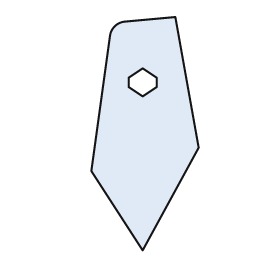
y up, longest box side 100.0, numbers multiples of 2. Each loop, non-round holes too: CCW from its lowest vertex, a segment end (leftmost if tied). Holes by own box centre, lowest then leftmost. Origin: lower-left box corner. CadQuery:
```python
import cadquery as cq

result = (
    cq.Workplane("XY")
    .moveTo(22.0, 0.0)
    .lineTo(46.0, 44.0)
    .lineTo(36.0, 100.0)
    .lineTo(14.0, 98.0)
    .threePointArc((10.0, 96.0), (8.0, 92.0))
    .lineTo(0.0, 34.0)
    .close()
    .moveTo(22.0, 66.0)
    .lineTo(28.0, 70.0)
    .lineTo(28.0, 74.0)
    .lineTo(22.0, 78.0)
    .lineTo(16.0, 74.0)
    .lineTo(16.0, 70.0)
    .close()
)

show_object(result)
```